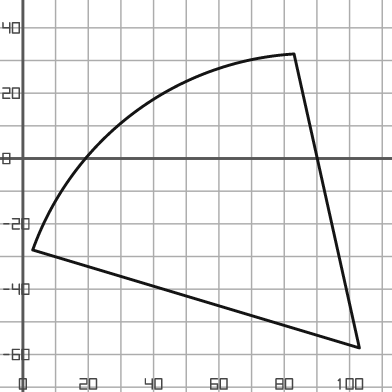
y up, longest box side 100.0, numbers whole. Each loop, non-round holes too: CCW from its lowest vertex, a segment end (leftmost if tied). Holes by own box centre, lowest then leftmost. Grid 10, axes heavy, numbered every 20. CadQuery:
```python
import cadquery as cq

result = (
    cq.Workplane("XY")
    .moveTo(103.0, -58.0)
    .lineTo(83.0, 32.0)
    .threePointArc((34.0, 14.0), (3.0, -28.0))
    .close()
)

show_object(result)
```